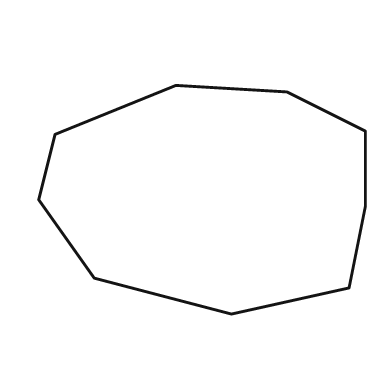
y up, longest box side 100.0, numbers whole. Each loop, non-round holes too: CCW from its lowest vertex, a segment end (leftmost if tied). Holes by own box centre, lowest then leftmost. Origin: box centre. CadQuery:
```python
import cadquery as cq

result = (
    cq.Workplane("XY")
    .moveTo(9.0, -35.0)
    .lineTo(45.0, -27.0)
    .lineTo(50.0, -2.0)
    .lineTo(50.0, 21.0)
    .lineTo(26.0, 33.0)
    .lineTo(-8.0, 35.0)
    .lineTo(-45.0, 20.0)
    .lineTo(-50.0, 0.0)
    .lineTo(-33.0, -24.0)
    .close()
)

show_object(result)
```